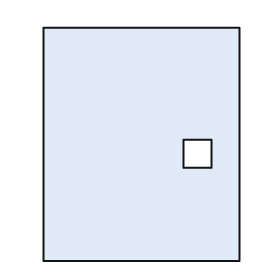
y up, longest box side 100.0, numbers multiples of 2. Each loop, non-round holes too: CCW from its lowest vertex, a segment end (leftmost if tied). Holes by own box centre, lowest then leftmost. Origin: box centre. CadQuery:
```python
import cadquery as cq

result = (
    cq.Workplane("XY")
    .moveTo(-42.0, -50.0)
    .lineTo(42.0, -50.0)
    .lineTo(42.0, 50.0)
    .lineTo(-42.0, 50.0)
    .close()
    .moveTo(18.0, -10.0)
    .lineTo(30.0, -10.0)
    .lineTo(30.0, 2.0)
    .lineTo(18.0, 2.0)
    .close()
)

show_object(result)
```